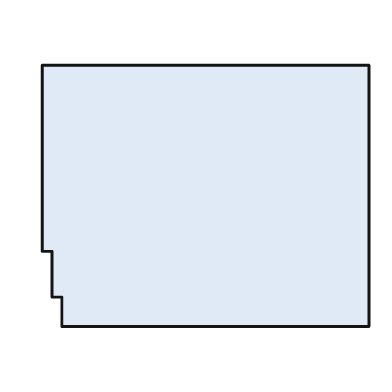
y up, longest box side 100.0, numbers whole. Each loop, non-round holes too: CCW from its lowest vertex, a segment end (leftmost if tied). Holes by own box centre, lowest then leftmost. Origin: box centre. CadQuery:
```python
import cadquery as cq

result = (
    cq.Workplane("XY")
    .moveTo(-44.0, -40.0)
    .lineTo(50.0, -40.0)
    .lineTo(50.0, 40.0)
    .lineTo(-50.0, 40.0)
    .lineTo(-50.0, -17.0)
    .lineTo(-47.0, -17.0)
    .lineTo(-47.0, -31.0)
    .lineTo(-44.0, -31.0)
    .close()
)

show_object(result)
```